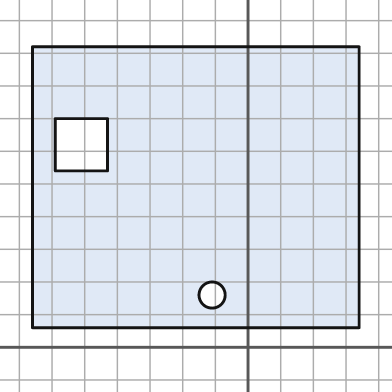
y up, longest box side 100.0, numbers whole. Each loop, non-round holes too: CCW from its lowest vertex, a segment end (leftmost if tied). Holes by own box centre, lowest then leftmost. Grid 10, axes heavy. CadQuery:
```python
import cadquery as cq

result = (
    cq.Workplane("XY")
    .moveTo(-66.0, 6.0)
    .lineTo(34.0, 6.0)
    .lineTo(34.0, 92.0)
    .lineTo(-66.0, 92.0)
    .close()
    .moveTo(-11.0, 16.0)
    .circle(4.0)
    .moveTo(-59.0, 54.0)
    .lineTo(-43.0, 54.0)
    .lineTo(-43.0, 70.0)
    .lineTo(-59.0, 70.0)
    .close()
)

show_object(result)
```